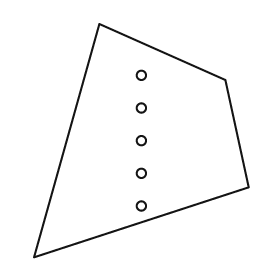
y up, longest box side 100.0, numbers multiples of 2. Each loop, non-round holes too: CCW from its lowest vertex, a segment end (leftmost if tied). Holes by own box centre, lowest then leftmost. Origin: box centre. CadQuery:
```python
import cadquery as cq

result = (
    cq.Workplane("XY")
    .moveTo(-46.0, -50.0)
    .lineTo(46.0, -20.0)
    .lineTo(36.0, 26.0)
    .lineTo(-18.0, 50.0)
    .close()
    .moveTo(0.0, -28.0)
    .circle(2.0)
    .moveTo(0.0, -14.0)
    .circle(2.0)
    .moveTo(0.0, 0.0)
    .circle(2.0)
    .moveTo(0.0, 14.0)
    .circle(2.0)
    .moveTo(0.0, 28.0)
    .circle(2.0)
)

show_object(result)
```